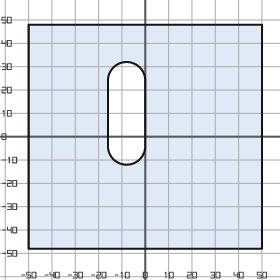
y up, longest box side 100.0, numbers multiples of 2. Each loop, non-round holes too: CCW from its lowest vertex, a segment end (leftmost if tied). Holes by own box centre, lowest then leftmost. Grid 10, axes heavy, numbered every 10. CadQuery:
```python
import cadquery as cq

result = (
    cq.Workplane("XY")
    .moveTo(-50.0, -48.0)
    .lineTo(50.0, -48.0)
    .lineTo(50.0, 48.0)
    .lineTo(-50.0, 48.0)
    .close()
    .moveTo(-16.0, -4.0)
    .threePointArc((-8.0, -12.0), (0.0, -4.0))
    .lineTo(0.0, 24.0)
    .threePointArc((-8.0, 32.0), (-16.0, 24.0))
    .close()
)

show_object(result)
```